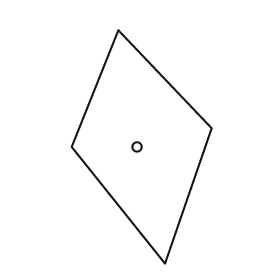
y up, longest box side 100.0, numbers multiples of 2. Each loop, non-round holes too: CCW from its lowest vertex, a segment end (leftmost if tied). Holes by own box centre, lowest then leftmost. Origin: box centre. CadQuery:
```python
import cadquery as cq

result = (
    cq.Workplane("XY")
    .moveTo(10.0, -50.0)
    .lineTo(30.0, 8.0)
    .lineTo(-10.0, 50.0)
    .lineTo(-30.0, 0.0)
    .close()
    .moveTo(-2.0, 0.0)
    .circle(2.0)
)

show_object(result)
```